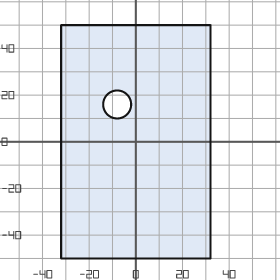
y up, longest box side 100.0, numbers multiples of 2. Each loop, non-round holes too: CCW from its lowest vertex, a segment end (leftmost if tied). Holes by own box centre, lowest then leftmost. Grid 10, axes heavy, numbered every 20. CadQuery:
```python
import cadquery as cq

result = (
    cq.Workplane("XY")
    .moveTo(-32.0, -50.0)
    .lineTo(32.0, -50.0)
    .lineTo(32.0, 50.0)
    .lineTo(-32.0, 50.0)
    .close()
    .moveTo(-8.0, 16.0)
    .circle(6.0)
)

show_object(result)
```